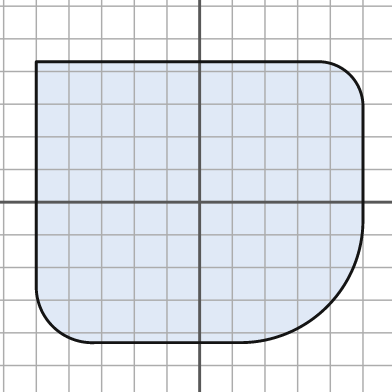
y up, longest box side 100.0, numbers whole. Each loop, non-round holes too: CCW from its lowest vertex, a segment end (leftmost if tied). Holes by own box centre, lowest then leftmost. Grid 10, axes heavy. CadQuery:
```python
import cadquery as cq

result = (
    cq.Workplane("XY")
    .moveTo(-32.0, -43.0)
    .lineTo(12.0, -43.0)
    .threePointArc((39.0, -32.0), (50.0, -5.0))
    .lineTo(50.0, 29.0)
    .threePointArc((46.0, 39.0), (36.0, 43.0))
    .lineTo(-50.0, 43.0)
    .lineTo(-50.0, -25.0)
    .threePointArc((-45.0, -38.0), (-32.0, -43.0))
    .close()
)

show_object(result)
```